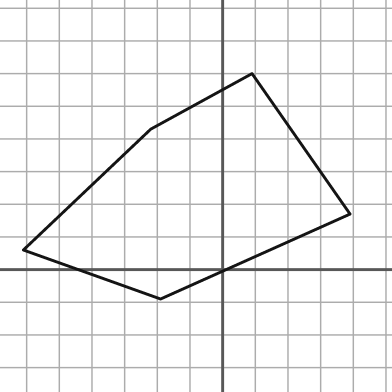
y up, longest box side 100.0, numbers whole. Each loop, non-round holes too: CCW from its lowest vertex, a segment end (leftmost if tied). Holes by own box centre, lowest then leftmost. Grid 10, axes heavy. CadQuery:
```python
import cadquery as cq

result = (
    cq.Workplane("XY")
    .moveTo(-19.0, -9.0)
    .lineTo(39.0, 17.0)
    .lineTo(9.0, 60.0)
    .lineTo(-22.0, 43.0)
    .lineTo(-61.0, 6.0)
    .close()
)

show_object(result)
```